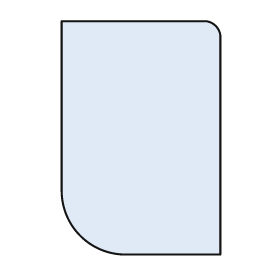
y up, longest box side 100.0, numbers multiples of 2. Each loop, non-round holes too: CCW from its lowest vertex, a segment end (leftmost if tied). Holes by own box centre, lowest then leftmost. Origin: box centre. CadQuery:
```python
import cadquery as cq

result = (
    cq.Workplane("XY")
    .moveTo(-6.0, -50.0)
    .lineTo(34.0, -50.0)
    .lineTo(34.0, 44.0)
    .threePointArc((32.0, 48.0), (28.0, 50.0))
    .lineTo(-34.0, 50.0)
    .lineTo(-34.0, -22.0)
    .threePointArc((-26.0, -42.0), (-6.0, -50.0))
    .close()
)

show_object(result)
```